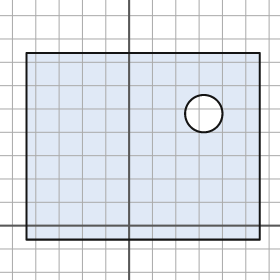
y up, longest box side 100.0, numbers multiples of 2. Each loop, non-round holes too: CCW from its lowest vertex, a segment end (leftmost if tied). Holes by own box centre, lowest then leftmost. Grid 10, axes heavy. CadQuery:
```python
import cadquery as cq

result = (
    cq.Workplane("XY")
    .moveTo(-44.0, -6.0)
    .lineTo(56.0, -6.0)
    .lineTo(56.0, 74.0)
    .lineTo(-44.0, 74.0)
    .close()
    .moveTo(32.0, 48.0)
    .circle(8.0)
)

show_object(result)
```